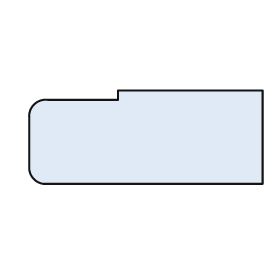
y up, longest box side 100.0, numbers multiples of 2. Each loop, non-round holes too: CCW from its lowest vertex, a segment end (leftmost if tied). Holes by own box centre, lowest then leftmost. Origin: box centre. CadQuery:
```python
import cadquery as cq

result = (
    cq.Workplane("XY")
    .moveTo(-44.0, -20.0)
    .lineTo(50.0, -20.0)
    .lineTo(50.0, 20.0)
    .lineTo(-12.0, 20.0)
    .lineTo(-12.0, 16.0)
    .lineTo(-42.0, 16.0)
    .threePointArc((-48.0, 14.0), (-50.0, 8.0))
    .lineTo(-50.0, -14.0)
    .threePointArc((-48.0, -18.0), (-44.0, -20.0))
    .close()
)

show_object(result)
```